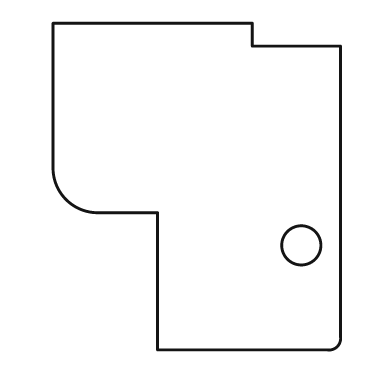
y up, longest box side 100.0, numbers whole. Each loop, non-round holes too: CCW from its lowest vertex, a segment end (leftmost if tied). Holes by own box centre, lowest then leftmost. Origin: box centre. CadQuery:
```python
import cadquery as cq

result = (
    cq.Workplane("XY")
    .moveTo(-12.0, -50.0)
    .lineTo(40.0, -50.0)
    .threePointArc((43.0, -49.0), (44.0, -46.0))
    .lineTo(44.0, 43.0)
    .lineTo(17.0, 43.0)
    .lineTo(17.0, 50.0)
    .lineTo(-44.0, 50.0)
    .lineTo(-44.0, 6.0)
    .threePointArc((-40.0, -4.0), (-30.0, -8.0))
    .lineTo(-12.0, -8.0)
    .close()
    .moveTo(32.0, -18.0)
    .circle(6.0)
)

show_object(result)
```